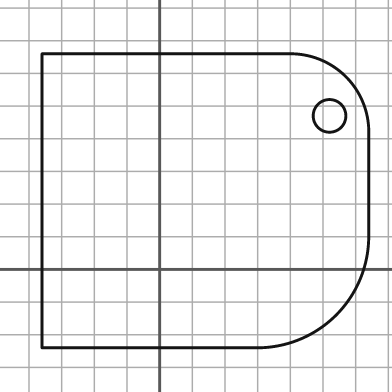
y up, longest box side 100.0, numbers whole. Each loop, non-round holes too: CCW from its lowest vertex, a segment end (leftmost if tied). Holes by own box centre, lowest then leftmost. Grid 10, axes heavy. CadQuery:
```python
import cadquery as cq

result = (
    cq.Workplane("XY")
    .moveTo(-36.0, -24.0)
    .lineTo(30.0, -24.0)
    .threePointArc((54.0, -14.0), (64.0, 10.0))
    .lineTo(64.0, 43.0)
    .threePointArc((57.0, 59.0), (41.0, 66.0))
    .lineTo(-36.0, 66.0)
    .close()
    .moveTo(52.0, 47.0)
    .circle(5.0)
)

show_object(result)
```